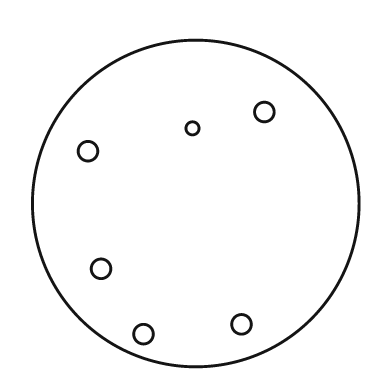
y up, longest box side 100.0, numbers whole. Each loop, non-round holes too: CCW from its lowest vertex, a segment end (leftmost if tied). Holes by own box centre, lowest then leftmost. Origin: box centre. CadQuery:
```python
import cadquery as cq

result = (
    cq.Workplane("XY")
    .moveTo(0.0, 0.0)
    .circle(50.0)
    .moveTo(-16.0, -40.0)
    .circle(3.0)
    .moveTo(14.0, -37.0)
    .circle(3.0)
    .moveTo(-29.0, -20.0)
    .circle(3.0)
    .moveTo(-33.0, 16.0)
    .circle(3.0)
    .moveTo(-1.0, 23.0)
    .circle(2.0)
    .moveTo(21.0, 28.0)
    .circle(3.0)
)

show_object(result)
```